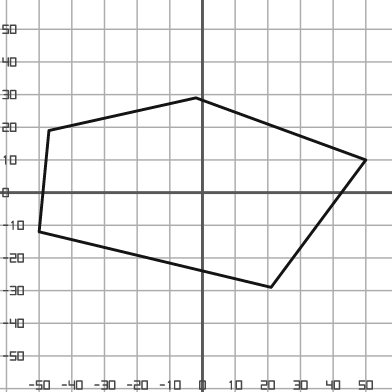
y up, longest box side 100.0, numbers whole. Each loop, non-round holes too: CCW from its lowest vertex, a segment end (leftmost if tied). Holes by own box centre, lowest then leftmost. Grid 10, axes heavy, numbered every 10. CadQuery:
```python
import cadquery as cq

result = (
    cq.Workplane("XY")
    .moveTo(21.0, -29.0)
    .lineTo(50.0, 10.0)
    .lineTo(-2.0, 29.0)
    .lineTo(-47.0, 19.0)
    .lineTo(-50.0, -12.0)
    .close()
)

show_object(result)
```